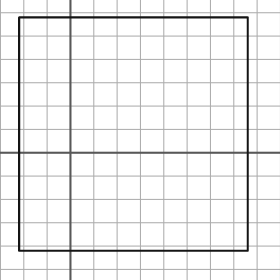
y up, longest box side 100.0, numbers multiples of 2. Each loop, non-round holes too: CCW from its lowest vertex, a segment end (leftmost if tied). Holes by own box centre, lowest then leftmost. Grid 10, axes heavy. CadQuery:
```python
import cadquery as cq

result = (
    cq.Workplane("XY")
    .moveTo(-22.0, -42.0)
    .lineTo(76.0, -42.0)
    .lineTo(76.0, 58.0)
    .lineTo(-22.0, 58.0)
    .close()
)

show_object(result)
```